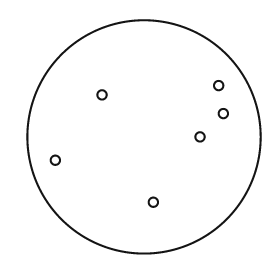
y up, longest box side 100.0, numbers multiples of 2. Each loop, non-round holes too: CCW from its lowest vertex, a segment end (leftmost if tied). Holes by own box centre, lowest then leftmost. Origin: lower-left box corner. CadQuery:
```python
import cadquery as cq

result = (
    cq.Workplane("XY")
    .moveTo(50.0, 50.0)
    .circle(50.0)
    .moveTo(54.0, 22.0)
    .circle(2.0)
    .moveTo(12.0, 40.0)
    .circle(2.0)
    .moveTo(74.0, 50.0)
    .circle(2.0)
    .moveTo(84.0, 60.0)
    .circle(2.0)
    .moveTo(32.0, 68.0)
    .circle(2.0)
    .moveTo(82.0, 72.0)
    .circle(2.0)
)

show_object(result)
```